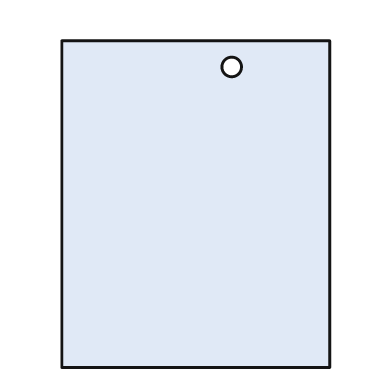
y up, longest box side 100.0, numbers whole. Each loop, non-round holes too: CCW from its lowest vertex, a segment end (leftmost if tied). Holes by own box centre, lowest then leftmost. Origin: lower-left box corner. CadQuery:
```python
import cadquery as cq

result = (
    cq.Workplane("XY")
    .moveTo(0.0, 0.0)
    .lineTo(82.0, 0.0)
    .lineTo(82.0, 100.0)
    .lineTo(0.0, 100.0)
    .close()
    .moveTo(52.0, 92.0)
    .circle(3.0)
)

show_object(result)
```